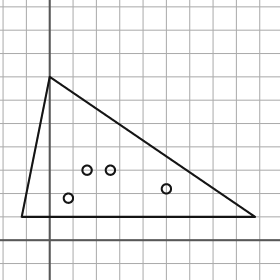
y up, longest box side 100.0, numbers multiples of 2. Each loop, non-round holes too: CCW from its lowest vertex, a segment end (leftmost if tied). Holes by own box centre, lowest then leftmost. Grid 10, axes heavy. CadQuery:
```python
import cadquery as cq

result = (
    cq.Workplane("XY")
    .moveTo(-12.0, 10.0)
    .lineTo(88.0, 10.0)
    .lineTo(0.0, 70.0)
    .close()
    .moveTo(8.0, 18.0)
    .circle(2.0)
    .moveTo(50.0, 22.0)
    .circle(2.0)
    .moveTo(16.0, 30.0)
    .circle(2.0)
    .moveTo(26.0, 30.0)
    .circle(2.0)
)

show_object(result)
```